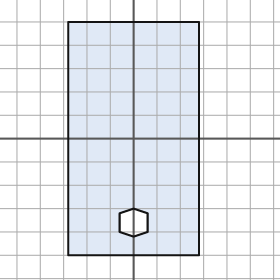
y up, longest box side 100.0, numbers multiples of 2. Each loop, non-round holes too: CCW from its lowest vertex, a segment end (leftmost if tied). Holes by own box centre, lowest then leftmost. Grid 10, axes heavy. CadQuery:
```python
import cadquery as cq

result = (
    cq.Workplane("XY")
    .moveTo(-28.0, -50.0)
    .lineTo(28.0, -50.0)
    .lineTo(28.0, 50.0)
    .lineTo(-28.0, 50.0)
    .close()
    .moveTo(0.0, -42.0)
    .lineTo(6.0, -40.0)
    .lineTo(6.0, -32.0)
    .lineTo(0.0, -30.0)
    .lineTo(-6.0, -32.0)
    .lineTo(-6.0, -40.0)
    .close()
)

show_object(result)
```